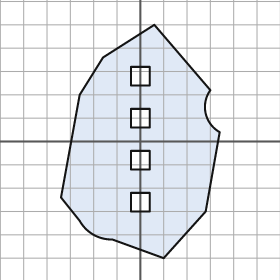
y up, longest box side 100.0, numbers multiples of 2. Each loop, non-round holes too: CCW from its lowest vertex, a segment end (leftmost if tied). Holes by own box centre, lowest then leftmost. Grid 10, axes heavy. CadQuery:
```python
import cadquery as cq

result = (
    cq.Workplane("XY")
    .moveTo(10.0, -50.0)
    .lineTo(28.0, -30.0)
    .lineTo(34.0, 4.0)
    .threePointArc((28.0, 12.0), (30.0, 22.0))
    .lineTo(6.0, 50.0)
    .lineTo(-16.0, 36.0)
    .lineTo(-26.0, 20.0)
    .lineTo(-34.0, -24.0)
    .lineTo(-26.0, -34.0)
    .threePointArc((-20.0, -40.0), (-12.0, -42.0))
    .close()
    .moveTo(-4.0, -30.0)
    .lineTo(4.0, -30.0)
    .lineTo(4.0, -22.0)
    .lineTo(-4.0, -22.0)
    .close()
    .moveTo(-4.0, -12.0)
    .lineTo(4.0, -12.0)
    .lineTo(4.0, -4.0)
    .lineTo(-4.0, -4.0)
    .close()
    .moveTo(-4.0, 6.0)
    .lineTo(4.0, 6.0)
    .lineTo(4.0, 14.0)
    .lineTo(-4.0, 14.0)
    .close()
    .moveTo(-4.0, 24.0)
    .lineTo(4.0, 24.0)
    .lineTo(4.0, 32.0)
    .lineTo(-4.0, 32.0)
    .close()
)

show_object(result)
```